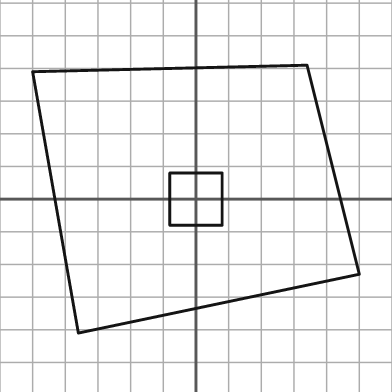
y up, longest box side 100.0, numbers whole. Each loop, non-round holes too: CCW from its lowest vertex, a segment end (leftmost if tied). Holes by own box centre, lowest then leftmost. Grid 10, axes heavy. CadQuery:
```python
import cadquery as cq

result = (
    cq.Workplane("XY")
    .moveTo(-36.0, -41.0)
    .lineTo(50.0, -23.0)
    .lineTo(34.0, 41.0)
    .lineTo(-50.0, 39.0)
    .close()
    .moveTo(-8.0, -8.0)
    .lineTo(8.0, -8.0)
    .lineTo(8.0, 8.0)
    .lineTo(-8.0, 8.0)
    .close()
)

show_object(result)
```